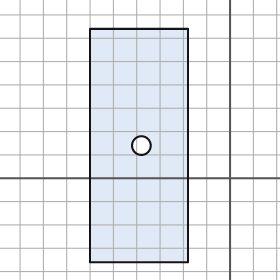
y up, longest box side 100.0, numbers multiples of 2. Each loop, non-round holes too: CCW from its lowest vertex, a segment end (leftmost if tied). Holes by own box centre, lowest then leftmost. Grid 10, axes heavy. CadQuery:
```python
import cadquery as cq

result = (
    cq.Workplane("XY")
    .moveTo(-60.0, -36.0)
    .lineTo(-18.0, -36.0)
    .lineTo(-18.0, 64.0)
    .lineTo(-60.0, 64.0)
    .close()
    .moveTo(-38.0, 14.0)
    .circle(4.0)
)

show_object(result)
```